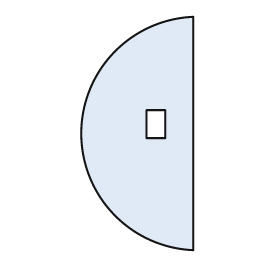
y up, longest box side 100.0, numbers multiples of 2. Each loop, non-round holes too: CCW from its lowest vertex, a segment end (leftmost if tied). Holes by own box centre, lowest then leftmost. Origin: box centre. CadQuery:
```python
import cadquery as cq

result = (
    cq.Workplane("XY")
    .moveTo(24.0, -50.0)
    .lineTo(24.0, 50.0)
    .threePointArc((-24.0, 0.0), (24.0, -50.0))
    .close()
    .moveTo(4.0, -2.0)
    .lineTo(12.0, -2.0)
    .lineTo(12.0, 10.0)
    .lineTo(4.0, 10.0)
    .close()
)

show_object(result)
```